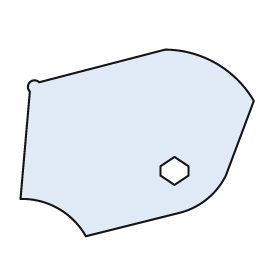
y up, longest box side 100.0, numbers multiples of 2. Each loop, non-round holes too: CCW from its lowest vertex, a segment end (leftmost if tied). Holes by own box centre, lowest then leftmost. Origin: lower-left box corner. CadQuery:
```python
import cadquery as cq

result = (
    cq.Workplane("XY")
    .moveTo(28.0, 0.0)
    .lineTo(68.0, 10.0)
    .threePointArc((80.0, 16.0), (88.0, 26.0))
    .lineTo(100.0, 58.0)
    .threePointArc((84.0, 74.0), (62.0, 80.0))
    .lineTo(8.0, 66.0)
    .threePointArc((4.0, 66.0), (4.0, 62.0))
    .lineTo(0.0, 16.0)
    .threePointArc((16.0, 12.0), (28.0, 0.0))
    .close()
    .moveTo(66.0, 22.0)
    .lineTo(72.0, 26.0)
    .lineTo(72.0, 30.0)
    .lineTo(66.0, 34.0)
    .lineTo(60.0, 30.0)
    .lineTo(60.0, 26.0)
    .close()
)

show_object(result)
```